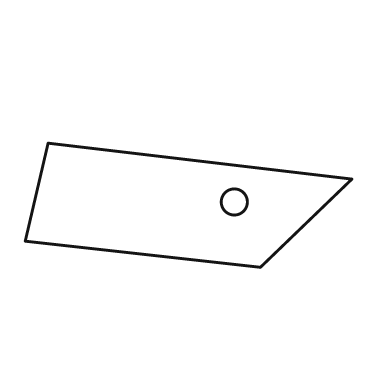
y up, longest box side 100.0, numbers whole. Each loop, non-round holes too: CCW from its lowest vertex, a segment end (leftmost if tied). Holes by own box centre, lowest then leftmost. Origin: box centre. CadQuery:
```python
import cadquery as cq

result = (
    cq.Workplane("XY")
    .moveTo(22.0, -19.0)
    .lineTo(50.0, 8.0)
    .lineTo(-43.0, 19.0)
    .lineTo(-50.0, -11.0)
    .close()
    .moveTo(14.0, 1.0)
    .circle(4.0)
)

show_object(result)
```